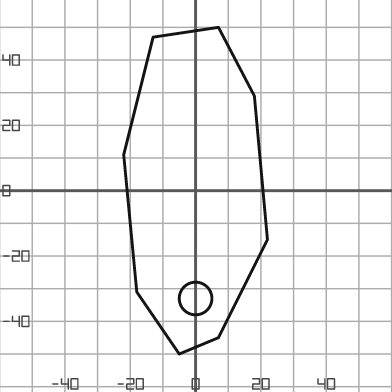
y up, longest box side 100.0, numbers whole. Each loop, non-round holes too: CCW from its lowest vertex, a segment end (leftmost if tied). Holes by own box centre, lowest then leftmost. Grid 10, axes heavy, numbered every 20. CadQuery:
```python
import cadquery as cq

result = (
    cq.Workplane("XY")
    .moveTo(-5.0, -50.0)
    .lineTo(7.0, -45.0)
    .lineTo(22.0, -15.0)
    .lineTo(18.0, 29.0)
    .lineTo(7.0, 50.0)
    .lineTo(-13.0, 47.0)
    .lineTo(-22.0, 11.0)
    .lineTo(-18.0, -31.0)
    .close()
    .moveTo(0.0, -33.0)
    .circle(5.0)
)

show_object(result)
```